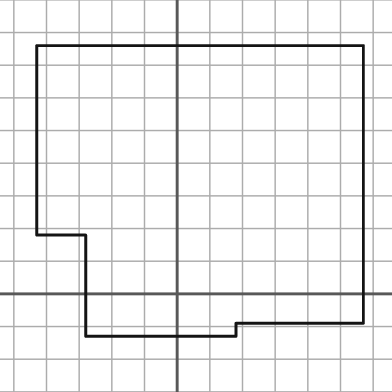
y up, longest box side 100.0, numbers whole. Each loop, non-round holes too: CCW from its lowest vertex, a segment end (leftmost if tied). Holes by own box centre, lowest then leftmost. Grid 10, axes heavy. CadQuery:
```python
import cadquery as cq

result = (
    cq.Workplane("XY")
    .moveTo(-28.0, -13.0)
    .lineTo(18.0, -13.0)
    .lineTo(18.0, -9.0)
    .lineTo(57.0, -9.0)
    .lineTo(57.0, 76.0)
    .lineTo(-43.0, 76.0)
    .lineTo(-43.0, 18.0)
    .lineTo(-28.0, 18.0)
    .close()
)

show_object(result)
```